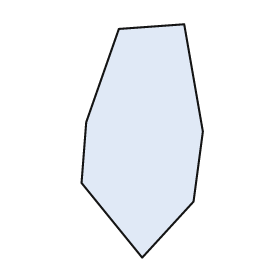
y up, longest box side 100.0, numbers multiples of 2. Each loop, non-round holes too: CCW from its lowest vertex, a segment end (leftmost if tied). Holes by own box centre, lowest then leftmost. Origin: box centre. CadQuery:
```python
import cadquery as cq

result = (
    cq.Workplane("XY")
    .moveTo(0.0, -50.0)
    .lineTo(22.0, -26.0)
    .lineTo(26.0, 4.0)
    .lineTo(18.0, 50.0)
    .lineTo(-10.0, 48.0)
    .lineTo(-24.0, 8.0)
    .lineTo(-26.0, -18.0)
    .close()
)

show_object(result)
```